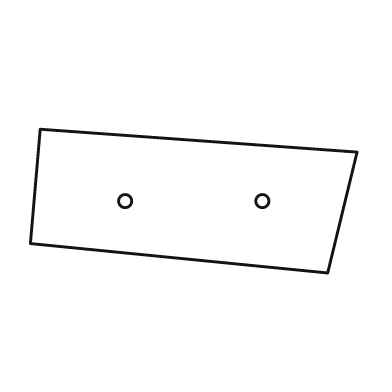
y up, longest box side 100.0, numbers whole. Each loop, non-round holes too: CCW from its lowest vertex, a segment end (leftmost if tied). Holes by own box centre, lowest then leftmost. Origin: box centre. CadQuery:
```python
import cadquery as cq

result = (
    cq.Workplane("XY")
    .moveTo(41.0, -22.0)
    .lineTo(50.0, 15.0)
    .lineTo(-47.0, 22.0)
    .lineTo(-50.0, -13.0)
    .close()
    .moveTo(-21.0, 0.0)
    .circle(2.0)
    .moveTo(21.0, 0.0)
    .circle(2.0)
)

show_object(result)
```